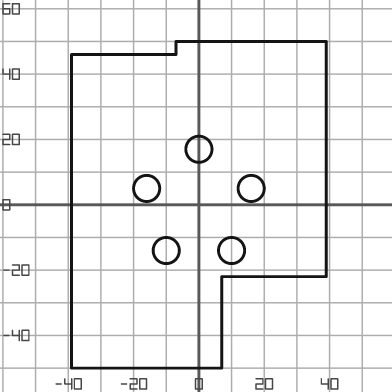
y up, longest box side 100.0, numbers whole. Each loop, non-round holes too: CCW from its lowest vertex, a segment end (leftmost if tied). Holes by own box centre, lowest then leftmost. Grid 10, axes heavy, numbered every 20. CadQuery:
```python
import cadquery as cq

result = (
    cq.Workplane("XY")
    .moveTo(-39.0, -50.0)
    .lineTo(7.0, -50.0)
    .lineTo(7.0, -22.0)
    .lineTo(39.0, -22.0)
    .lineTo(39.0, 50.0)
    .lineTo(-7.0, 50.0)
    .lineTo(-7.0, 46.0)
    .lineTo(-39.0, 46.0)
    .close()
    .moveTo(-10.0, -14.0)
    .circle(4.0)
    .moveTo(10.0, -14.0)
    .circle(4.0)
    .moveTo(-16.0, 5.0)
    .circle(4.0)
    .moveTo(16.0, 5.0)
    .circle(4.0)
    .moveTo(0.0, 17.0)
    .circle(4.0)
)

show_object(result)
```